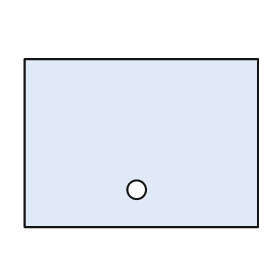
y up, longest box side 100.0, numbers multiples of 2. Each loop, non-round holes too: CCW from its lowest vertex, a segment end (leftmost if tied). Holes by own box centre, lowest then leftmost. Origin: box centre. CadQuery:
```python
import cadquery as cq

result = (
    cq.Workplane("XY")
    .moveTo(-50.0, -36.0)
    .lineTo(50.0, -36.0)
    .lineTo(50.0, 36.0)
    .lineTo(-50.0, 36.0)
    .close()
    .moveTo(-2.0, -20.0)
    .circle(4.0)
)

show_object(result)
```